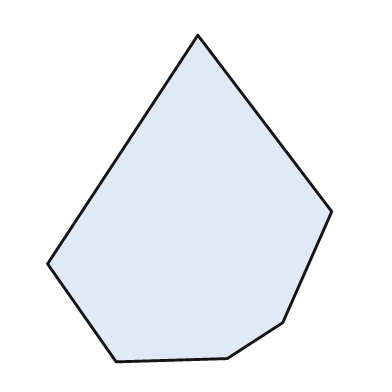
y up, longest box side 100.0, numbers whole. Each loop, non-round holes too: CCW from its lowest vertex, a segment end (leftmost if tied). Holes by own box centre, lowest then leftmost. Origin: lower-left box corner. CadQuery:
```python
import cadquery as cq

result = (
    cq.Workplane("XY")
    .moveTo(21.0, 0.0)
    .lineTo(55.0, 1.0)
    .lineTo(72.0, 12.0)
    .lineTo(87.0, 46.0)
    .lineTo(46.0, 100.0)
    .lineTo(0.0, 30.0)
    .close()
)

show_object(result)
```